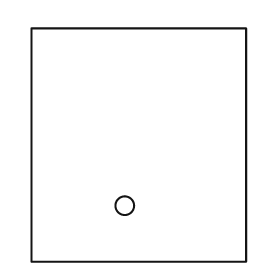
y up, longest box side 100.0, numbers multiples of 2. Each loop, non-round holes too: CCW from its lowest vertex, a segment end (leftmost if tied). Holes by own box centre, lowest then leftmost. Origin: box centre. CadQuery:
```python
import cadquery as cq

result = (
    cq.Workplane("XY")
    .moveTo(-46.0, -50.0)
    .lineTo(46.0, -50.0)
    .lineTo(46.0, 50.0)
    .lineTo(-46.0, 50.0)
    .close()
    .moveTo(-6.0, -26.0)
    .circle(4.0)
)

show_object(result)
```